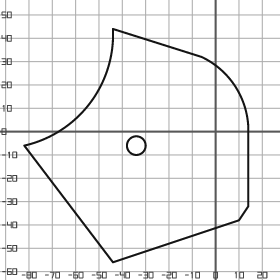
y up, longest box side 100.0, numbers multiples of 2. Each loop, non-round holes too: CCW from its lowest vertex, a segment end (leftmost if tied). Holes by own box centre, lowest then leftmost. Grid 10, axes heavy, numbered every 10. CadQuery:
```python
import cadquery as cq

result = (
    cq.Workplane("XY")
    .moveTo(-44.0, -56.0)
    .lineTo(10.0, -38.0)
    .lineTo(14.0, -32.0)
    .lineTo(14.0, 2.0)
    .threePointArc((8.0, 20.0), (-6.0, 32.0))
    .lineTo(-44.0, 44.0)
    .threePointArc((-54.0, 12.0), (-82.0, -6.0))
    .close()
    .moveTo(-34.0, -6.0)
    .circle(4.0)
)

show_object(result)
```